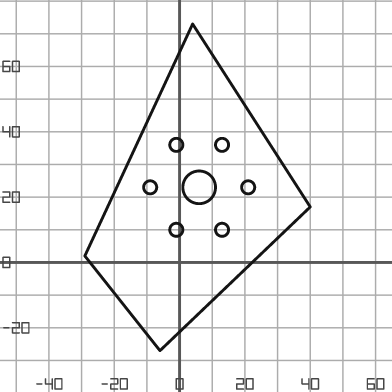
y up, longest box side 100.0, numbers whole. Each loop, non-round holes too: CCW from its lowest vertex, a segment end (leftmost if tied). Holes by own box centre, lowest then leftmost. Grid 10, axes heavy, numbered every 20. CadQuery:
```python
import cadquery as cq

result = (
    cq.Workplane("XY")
    .moveTo(-6.0, -27.0)
    .lineTo(40.0, 17.0)
    .lineTo(4.0, 73.0)
    .lineTo(-29.0, 2.0)
    .close()
    .moveTo(-1.0, 10.0)
    .circle(2.0)
    .moveTo(13.0, 10.0)
    .circle(2.0)
    .moveTo(-9.0, 23.0)
    .circle(2.0)
    .moveTo(6.0, 23.0)
    .circle(5.0)
    .moveTo(21.0, 23.0)
    .circle(2.0)
    .moveTo(-1.0, 36.0)
    .circle(2.0)
    .moveTo(13.0, 36.0)
    .circle(2.0)
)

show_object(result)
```